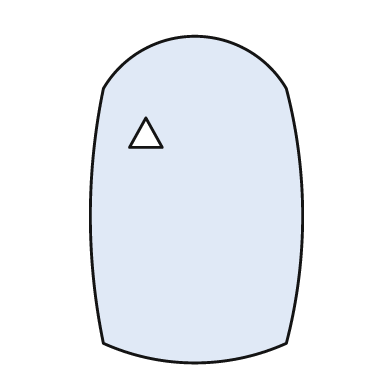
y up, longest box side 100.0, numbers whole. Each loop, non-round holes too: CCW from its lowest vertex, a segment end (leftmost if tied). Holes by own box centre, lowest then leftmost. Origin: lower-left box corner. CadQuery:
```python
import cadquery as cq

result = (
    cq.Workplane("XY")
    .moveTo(4.0, 6.0)
    .threePointArc((32.0, 0.0), (60.0, 6.0))
    .threePointArc((65.0, 45.0), (60.0, 84.0))
    .threePointArc((32.0, 100.0), (4.0, 84.0))
    .threePointArc((0.0, 45.0), (4.0, 6.0))
    .close()
    .moveTo(12.0, 66.0)
    .lineTo(22.0, 66.0)
    .lineTo(17.0, 75.0)
    .close()
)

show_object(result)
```